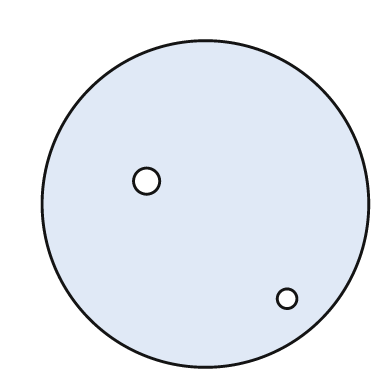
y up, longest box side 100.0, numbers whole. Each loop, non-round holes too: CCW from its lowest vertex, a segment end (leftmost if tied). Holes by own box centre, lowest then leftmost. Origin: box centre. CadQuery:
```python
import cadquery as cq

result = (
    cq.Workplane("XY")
    .moveTo(0.0, 0.0)
    .circle(50.0)
    .moveTo(25.0, -29.0)
    .circle(3.0)
    .moveTo(-18.0, 7.0)
    .circle(4.0)
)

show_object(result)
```